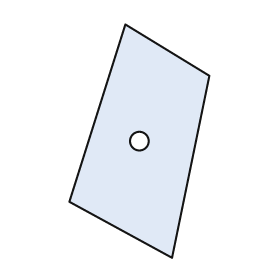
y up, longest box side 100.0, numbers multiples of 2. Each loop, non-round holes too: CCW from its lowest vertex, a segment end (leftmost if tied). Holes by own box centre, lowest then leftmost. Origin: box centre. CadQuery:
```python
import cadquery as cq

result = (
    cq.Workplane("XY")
    .moveTo(14.0, -50.0)
    .lineTo(30.0, 28.0)
    .lineTo(-6.0, 50.0)
    .lineTo(-30.0, -26.0)
    .close()
    .moveTo(0.0, 0.0)
    .circle(4.0)
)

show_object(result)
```